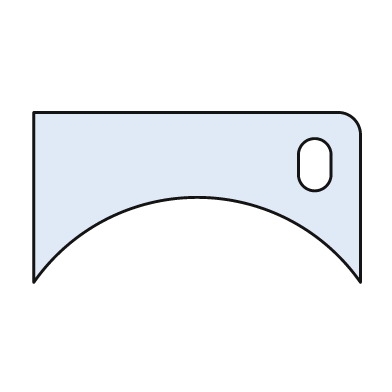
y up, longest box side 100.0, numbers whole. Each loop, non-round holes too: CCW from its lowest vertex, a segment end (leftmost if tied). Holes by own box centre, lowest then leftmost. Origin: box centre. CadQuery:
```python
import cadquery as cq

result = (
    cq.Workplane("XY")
    .moveTo(-50.0, -26.0)
    .threePointArc((0.0, 0.0), (50.0, -26.0))
    .lineTo(50.0, 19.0)
    .threePointArc((48.0, 24.0), (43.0, 26.0))
    .lineTo(-50.0, 26.0)
    .close()
    .moveTo(31.0, 7.0)
    .threePointArc((36.0, 2.0), (41.0, 7.0))
    .lineTo(41.0, 13.0)
    .threePointArc((36.0, 18.0), (31.0, 13.0))
    .close()
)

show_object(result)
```